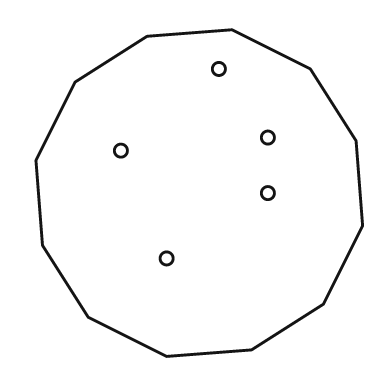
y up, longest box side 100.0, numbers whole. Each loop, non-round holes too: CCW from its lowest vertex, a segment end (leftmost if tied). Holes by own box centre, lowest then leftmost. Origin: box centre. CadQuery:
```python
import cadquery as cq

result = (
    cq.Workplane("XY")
    .moveTo(-10.0, -50.0)
    .lineTo(16.0, -48.0)
    .lineTo(38.0, -34.0)
    .lineTo(50.0, -10.0)
    .lineTo(48.0, 16.0)
    .lineTo(34.0, 38.0)
    .lineTo(10.0, 50.0)
    .lineTo(-16.0, 48.0)
    .lineTo(-38.0, 34.0)
    .lineTo(-50.0, 10.0)
    .lineTo(-48.0, -16.0)
    .lineTo(-34.0, -38.0)
    .close()
    .moveTo(-10.0, -20.0)
    .circle(2.0)
    .moveTo(21.0, 0.0)
    .circle(2.0)
    .moveTo(-24.0, 13.0)
    .circle(2.0)
    .moveTo(21.0, 17.0)
    .circle(2.0)
    .moveTo(6.0, 38.0)
    .circle(2.0)
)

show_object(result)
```